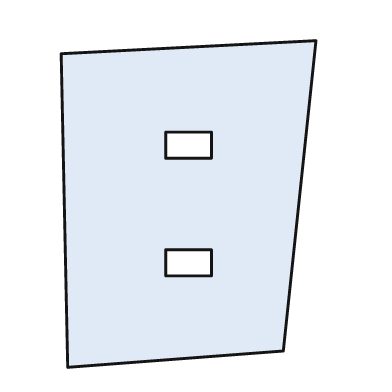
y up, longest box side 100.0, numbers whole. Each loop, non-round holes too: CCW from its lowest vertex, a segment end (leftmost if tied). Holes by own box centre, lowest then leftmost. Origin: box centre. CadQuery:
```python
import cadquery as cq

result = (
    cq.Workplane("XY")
    .moveTo(-37.0, -50.0)
    .lineTo(29.0, -45.0)
    .lineTo(39.0, 50.0)
    .lineTo(-39.0, 46.0)
    .close()
    .moveTo(-7.0, -22.0)
    .lineTo(7.0, -22.0)
    .lineTo(7.0, -14.0)
    .lineTo(-7.0, -14.0)
    .close()
    .moveTo(-7.0, 14.0)
    .lineTo(7.0, 14.0)
    .lineTo(7.0, 22.0)
    .lineTo(-7.0, 22.0)
    .close()
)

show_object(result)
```